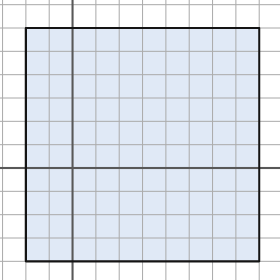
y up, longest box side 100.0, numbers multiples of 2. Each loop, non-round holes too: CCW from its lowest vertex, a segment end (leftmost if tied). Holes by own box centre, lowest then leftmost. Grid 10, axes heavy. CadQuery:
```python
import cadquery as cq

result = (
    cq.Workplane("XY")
    .moveTo(-20.0, -40.0)
    .lineTo(80.0, -40.0)
    .lineTo(80.0, 60.0)
    .lineTo(-20.0, 60.0)
    .close()
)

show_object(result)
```